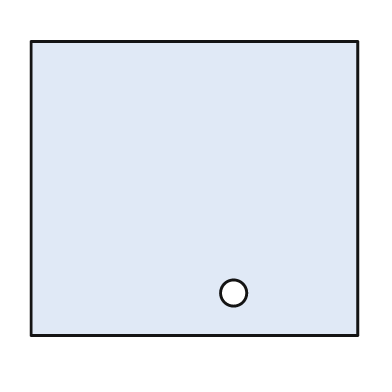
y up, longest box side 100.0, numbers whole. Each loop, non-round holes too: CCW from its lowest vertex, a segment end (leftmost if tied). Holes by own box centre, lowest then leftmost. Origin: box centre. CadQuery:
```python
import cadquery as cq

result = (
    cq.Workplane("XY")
    .moveTo(-50.0, -45.0)
    .lineTo(50.0, -45.0)
    .lineTo(50.0, 45.0)
    .lineTo(-50.0, 45.0)
    .close()
    .moveTo(12.0, -32.0)
    .circle(4.0)
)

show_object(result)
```